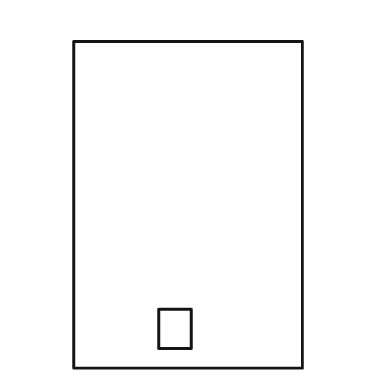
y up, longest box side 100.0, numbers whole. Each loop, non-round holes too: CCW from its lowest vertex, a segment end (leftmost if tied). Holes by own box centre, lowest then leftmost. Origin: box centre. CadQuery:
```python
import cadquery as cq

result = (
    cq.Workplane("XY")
    .moveTo(-35.0, -50.0)
    .lineTo(35.0, -50.0)
    .lineTo(35.0, 50.0)
    .lineTo(-35.0, 50.0)
    .close()
    .moveTo(-9.0, -44.0)
    .lineTo(1.0, -44.0)
    .lineTo(1.0, -32.0)
    .lineTo(-9.0, -32.0)
    .close()
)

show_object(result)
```